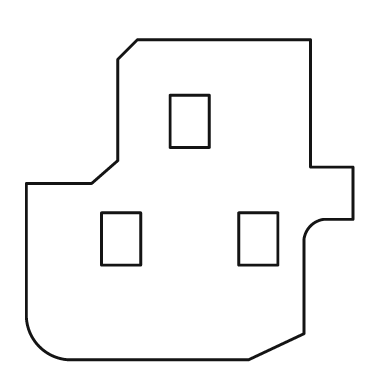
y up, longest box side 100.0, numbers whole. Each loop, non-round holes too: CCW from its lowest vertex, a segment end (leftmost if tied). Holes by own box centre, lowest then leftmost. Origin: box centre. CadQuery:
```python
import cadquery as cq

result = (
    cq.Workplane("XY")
    .moveTo(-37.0, -49.0)
    .lineTo(18.0, -49.0)
    .lineTo(35.0, -41.0)
    .lineTo(35.0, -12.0)
    .threePointArc((37.0, -8.0), (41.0, -6.0))
    .lineTo(50.0, -6.0)
    .lineTo(50.0, 10.0)
    .lineTo(37.0, 10.0)
    .lineTo(37.0, 49.0)
    .lineTo(-16.0, 49.0)
    .lineTo(-22.0, 43.0)
    .lineTo(-22.0, 12.0)
    .lineTo(-30.0, 5.0)
    .lineTo(-50.0, 5.0)
    .lineTo(-50.0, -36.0)
    .threePointArc((-46.0, -45.0), (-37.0, -49.0))
    .close()
    .moveTo(-27.0, -20.0)
    .lineTo(-15.0, -20.0)
    .lineTo(-15.0, -4.0)
    .lineTo(-27.0, -4.0)
    .close()
    .moveTo(15.0, -20.0)
    .lineTo(27.0, -20.0)
    .lineTo(27.0, -4.0)
    .lineTo(15.0, -4.0)
    .close()
    .moveTo(-6.0, 16.0)
    .lineTo(6.0, 16.0)
    .lineTo(6.0, 32.0)
    .lineTo(-6.0, 32.0)
    .close()
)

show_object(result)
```